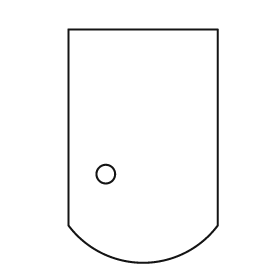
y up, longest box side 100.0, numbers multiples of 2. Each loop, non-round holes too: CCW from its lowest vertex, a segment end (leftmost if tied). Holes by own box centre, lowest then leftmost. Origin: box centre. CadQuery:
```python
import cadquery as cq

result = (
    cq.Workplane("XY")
    .moveTo(-32.0, -34.0)
    .threePointArc((0.0, -50.0), (32.0, -34.0))
    .lineTo(32.0, 50.0)
    .lineTo(-32.0, 50.0)
    .close()
    .moveTo(-16.0, -12.0)
    .circle(4.0)
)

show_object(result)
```